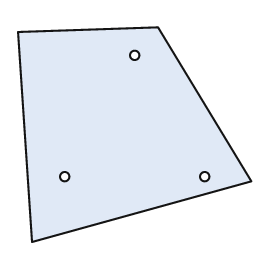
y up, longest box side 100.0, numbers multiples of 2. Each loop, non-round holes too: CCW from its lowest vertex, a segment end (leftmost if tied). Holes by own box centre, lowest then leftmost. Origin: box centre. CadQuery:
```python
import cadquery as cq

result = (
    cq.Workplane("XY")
    .moveTo(-44.0, -46.0)
    .lineTo(50.0, -20.0)
    .lineTo(10.0, 46.0)
    .lineTo(-50.0, 44.0)
    .close()
    .moveTo(-30.0, -18.0)
    .circle(2.0)
    .moveTo(30.0, -18.0)
    .circle(2.0)
    .moveTo(0.0, 34.0)
    .circle(2.0)
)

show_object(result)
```